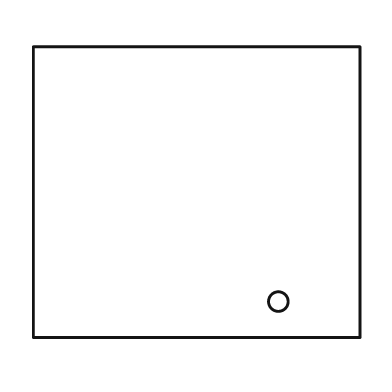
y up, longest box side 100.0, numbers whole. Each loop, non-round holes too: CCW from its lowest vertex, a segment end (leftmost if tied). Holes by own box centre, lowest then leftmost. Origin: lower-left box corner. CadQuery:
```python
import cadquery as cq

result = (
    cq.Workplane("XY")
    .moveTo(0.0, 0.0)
    .lineTo(100.0, 0.0)
    .lineTo(100.0, 89.0)
    .lineTo(0.0, 89.0)
    .close()
    .moveTo(75.0, 11.0)
    .circle(3.0)
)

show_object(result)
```